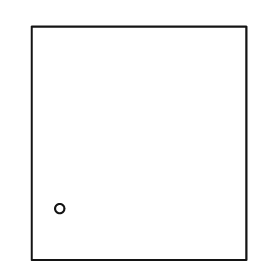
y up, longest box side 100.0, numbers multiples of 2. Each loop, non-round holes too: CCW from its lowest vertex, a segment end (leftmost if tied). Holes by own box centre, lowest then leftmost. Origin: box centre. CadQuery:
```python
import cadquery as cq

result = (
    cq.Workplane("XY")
    .moveTo(-46.0, -50.0)
    .lineTo(46.0, -50.0)
    .lineTo(46.0, 50.0)
    .lineTo(-46.0, 50.0)
    .close()
    .moveTo(-34.0, -28.0)
    .circle(2.0)
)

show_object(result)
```